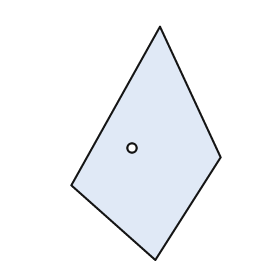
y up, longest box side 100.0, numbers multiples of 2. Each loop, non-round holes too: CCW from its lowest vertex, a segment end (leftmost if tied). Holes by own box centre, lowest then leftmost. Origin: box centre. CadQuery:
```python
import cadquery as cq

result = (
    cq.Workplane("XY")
    .moveTo(4.0, -50.0)
    .lineTo(32.0, -6.0)
    .lineTo(6.0, 50.0)
    .lineTo(-32.0, -18.0)
    .close()
    .moveTo(-6.0, -2.0)
    .circle(2.0)
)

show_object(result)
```